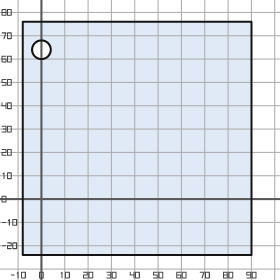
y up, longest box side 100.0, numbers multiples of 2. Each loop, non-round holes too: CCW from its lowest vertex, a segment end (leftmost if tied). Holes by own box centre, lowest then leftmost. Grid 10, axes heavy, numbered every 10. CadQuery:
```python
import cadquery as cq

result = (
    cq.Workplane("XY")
    .moveTo(-8.0, -24.0)
    .lineTo(90.0, -24.0)
    .lineTo(90.0, 76.0)
    .lineTo(-8.0, 76.0)
    .close()
    .moveTo(0.0, 64.0)
    .circle(4.0)
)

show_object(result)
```